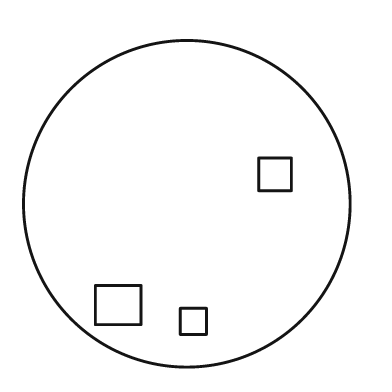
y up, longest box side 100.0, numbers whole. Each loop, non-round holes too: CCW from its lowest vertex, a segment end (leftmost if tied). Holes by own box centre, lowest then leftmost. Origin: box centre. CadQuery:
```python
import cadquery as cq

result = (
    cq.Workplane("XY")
    .moveTo(0.0, 0.0)
    .circle(50.0)
    .moveTo(-2.0, -40.0)
    .lineTo(6.0, -40.0)
    .lineTo(6.0, -32.0)
    .lineTo(-2.0, -32.0)
    .close()
    .moveTo(-28.0, -37.0)
    .lineTo(-14.0, -37.0)
    .lineTo(-14.0, -25.0)
    .lineTo(-28.0, -25.0)
    .close()
    .moveTo(22.0, 4.0)
    .lineTo(32.0, 4.0)
    .lineTo(32.0, 14.0)
    .lineTo(22.0, 14.0)
    .close()
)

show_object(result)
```